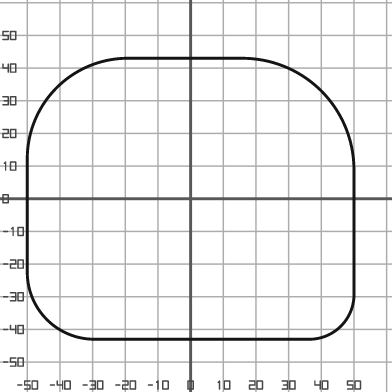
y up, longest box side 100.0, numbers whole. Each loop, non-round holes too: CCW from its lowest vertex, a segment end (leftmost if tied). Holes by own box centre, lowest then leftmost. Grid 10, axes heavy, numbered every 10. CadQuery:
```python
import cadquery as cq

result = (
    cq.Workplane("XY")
    .moveTo(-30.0, -43.0)
    .lineTo(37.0, -43.0)
    .threePointArc((46.0, -39.0), (50.0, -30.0))
    .lineTo(50.0, 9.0)
    .threePointArc((40.0, 33.0), (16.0, 43.0))
    .lineTo(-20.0, 43.0)
    .threePointArc((-41.0, 34.0), (-50.0, 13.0))
    .lineTo(-50.0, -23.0)
    .threePointArc((-44.0, -37.0), (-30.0, -43.0))
    .close()
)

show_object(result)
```